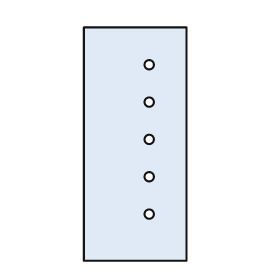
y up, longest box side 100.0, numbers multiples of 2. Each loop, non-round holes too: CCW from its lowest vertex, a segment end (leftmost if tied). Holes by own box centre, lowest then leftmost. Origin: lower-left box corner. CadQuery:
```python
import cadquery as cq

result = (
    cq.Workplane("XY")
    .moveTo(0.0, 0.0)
    .lineTo(44.0, 0.0)
    .lineTo(44.0, 100.0)
    .lineTo(0.0, 100.0)
    .close()
    .moveTo(28.0, 20.0)
    .circle(2.0)
    .moveTo(28.0, 36.0)
    .circle(2.0)
    .moveTo(28.0, 52.0)
    .circle(2.0)
    .moveTo(28.0, 68.0)
    .circle(2.0)
    .moveTo(28.0, 84.0)
    .circle(2.0)
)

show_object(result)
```